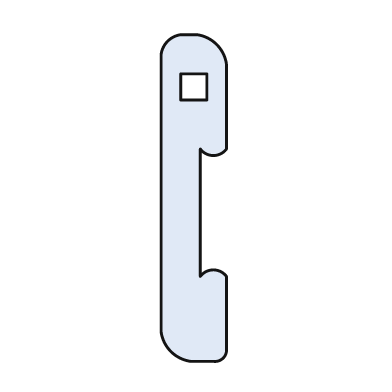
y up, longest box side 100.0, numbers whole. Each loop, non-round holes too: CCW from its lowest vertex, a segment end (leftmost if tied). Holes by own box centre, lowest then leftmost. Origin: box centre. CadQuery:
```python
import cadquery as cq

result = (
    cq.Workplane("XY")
    .moveTo(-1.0, -50.0)
    .lineTo(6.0, -50.0)
    .threePointArc((9.0, -49.0), (10.0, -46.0))
    .lineTo(10.0, -24.0)
    .threePointArc((6.0, -22.0), (2.0, -24.0))
    .lineTo(2.0, 15.0)
    .threePointArc((6.0, 13.0), (10.0, 15.0))
    .lineTo(10.0, 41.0)
    .threePointArc((7.0, 47.0), (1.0, 50.0))
    .lineTo(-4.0, 50.0)
    .threePointArc((-8.0, 48.0), (-10.0, 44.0))
    .lineTo(-10.0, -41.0)
    .threePointArc((-7.0, -47.0), (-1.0, -50.0))
    .close()
    .moveTo(-4.0, 30.0)
    .lineTo(4.0, 30.0)
    .lineTo(4.0, 38.0)
    .lineTo(-4.0, 38.0)
    .close()
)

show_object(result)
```